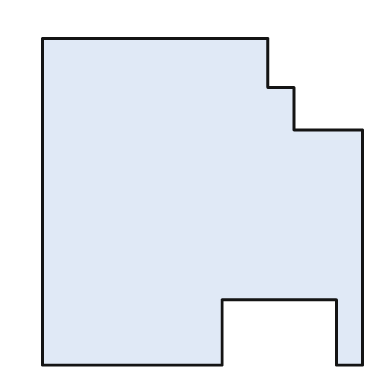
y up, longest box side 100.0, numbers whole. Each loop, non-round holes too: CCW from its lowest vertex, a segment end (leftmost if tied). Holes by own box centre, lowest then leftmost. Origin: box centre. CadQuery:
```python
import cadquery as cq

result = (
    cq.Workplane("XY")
    .moveTo(-49.0, -50.0)
    .lineTo(6.0, -50.0)
    .lineTo(6.0, -30.0)
    .lineTo(41.0, -30.0)
    .lineTo(41.0, -50.0)
    .lineTo(49.0, -50.0)
    .lineTo(49.0, 22.0)
    .lineTo(28.0, 22.0)
    .lineTo(28.0, 35.0)
    .lineTo(20.0, 35.0)
    .lineTo(20.0, 50.0)
    .lineTo(-49.0, 50.0)
    .close()
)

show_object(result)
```